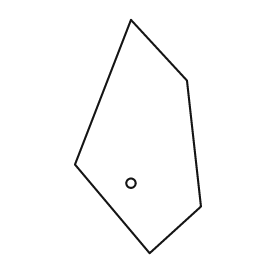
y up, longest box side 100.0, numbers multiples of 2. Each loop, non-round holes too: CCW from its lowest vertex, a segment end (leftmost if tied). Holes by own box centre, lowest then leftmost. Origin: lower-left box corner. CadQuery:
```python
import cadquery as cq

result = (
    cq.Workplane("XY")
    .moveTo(32.0, 0.0)
    .lineTo(54.0, 20.0)
    .lineTo(48.0, 74.0)
    .lineTo(24.0, 100.0)
    .lineTo(0.0, 38.0)
    .close()
    .moveTo(24.0, 30.0)
    .circle(2.0)
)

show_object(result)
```